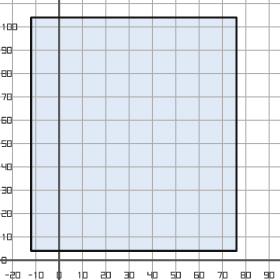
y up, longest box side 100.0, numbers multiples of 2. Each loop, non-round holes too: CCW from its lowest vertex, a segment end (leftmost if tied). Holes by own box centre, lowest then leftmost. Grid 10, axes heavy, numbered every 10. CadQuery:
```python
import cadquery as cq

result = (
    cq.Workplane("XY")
    .moveTo(-12.0, 4.0)
    .lineTo(76.0, 4.0)
    .lineTo(76.0, 104.0)
    .lineTo(-12.0, 104.0)
    .close()
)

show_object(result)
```